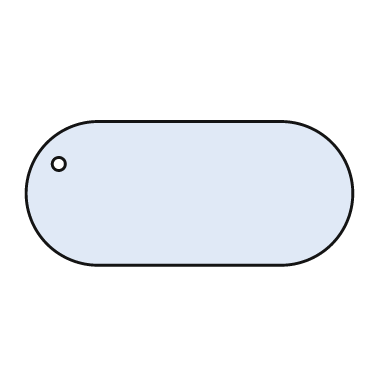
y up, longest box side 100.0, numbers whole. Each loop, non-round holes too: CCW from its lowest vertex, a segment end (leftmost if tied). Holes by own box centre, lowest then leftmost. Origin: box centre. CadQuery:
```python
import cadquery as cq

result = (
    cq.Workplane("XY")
    .moveTo(-28.0, -22.0)
    .lineTo(28.0, -22.0)
    .threePointArc((50.0, 0.0), (28.0, 22.0))
    .lineTo(-28.0, 22.0)
    .threePointArc((-50.0, 0.0), (-28.0, -22.0))
    .close()
    .moveTo(-40.0, 9.0)
    .circle(2.0)
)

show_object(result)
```